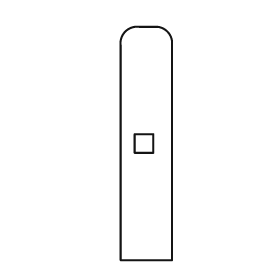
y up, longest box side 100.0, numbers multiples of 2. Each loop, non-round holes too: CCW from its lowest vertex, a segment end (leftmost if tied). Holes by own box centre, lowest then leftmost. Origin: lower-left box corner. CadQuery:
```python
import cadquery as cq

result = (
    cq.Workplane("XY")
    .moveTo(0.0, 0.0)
    .lineTo(22.0, 0.0)
    .lineTo(22.0, 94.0)
    .threePointArc((20.0, 98.0), (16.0, 100.0))
    .lineTo(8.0, 100.0)
    .threePointArc((2.0, 98.0), (0.0, 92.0))
    .close()
    .moveTo(6.0, 46.0)
    .lineTo(14.0, 46.0)
    .lineTo(14.0, 54.0)
    .lineTo(6.0, 54.0)
    .close()
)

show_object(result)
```